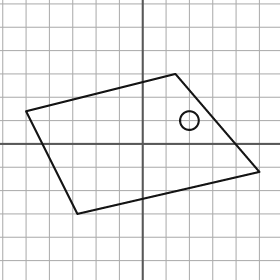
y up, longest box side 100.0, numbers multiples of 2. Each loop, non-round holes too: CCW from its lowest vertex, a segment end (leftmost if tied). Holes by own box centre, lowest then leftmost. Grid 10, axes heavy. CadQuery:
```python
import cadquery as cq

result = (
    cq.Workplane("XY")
    .moveTo(-28.0, -30.0)
    .lineTo(50.0, -12.0)
    .lineTo(14.0, 30.0)
    .lineTo(-50.0, 14.0)
    .close()
    .moveTo(20.0, 10.0)
    .circle(4.0)
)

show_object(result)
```